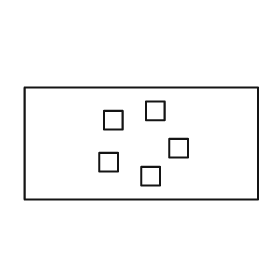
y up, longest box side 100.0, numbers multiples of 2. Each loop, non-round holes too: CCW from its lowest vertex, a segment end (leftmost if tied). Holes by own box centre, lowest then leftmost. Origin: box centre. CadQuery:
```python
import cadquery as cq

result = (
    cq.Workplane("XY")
    .moveTo(-50.0, -24.0)
    .lineTo(50.0, -24.0)
    .lineTo(50.0, 24.0)
    .lineTo(-50.0, 24.0)
    .close()
    .moveTo(0.0, -18.0)
    .lineTo(8.0, -18.0)
    .lineTo(8.0, -10.0)
    .lineTo(0.0, -10.0)
    .close()
    .moveTo(-18.0, -12.0)
    .lineTo(-10.0, -12.0)
    .lineTo(-10.0, -4.0)
    .lineTo(-18.0, -4.0)
    .close()
    .moveTo(12.0, -6.0)
    .lineTo(20.0, -6.0)
    .lineTo(20.0, 2.0)
    .lineTo(12.0, 2.0)
    .close()
    .moveTo(-16.0, 6.0)
    .lineTo(-8.0, 6.0)
    .lineTo(-8.0, 14.0)
    .lineTo(-16.0, 14.0)
    .close()
    .moveTo(2.0, 10.0)
    .lineTo(10.0, 10.0)
    .lineTo(10.0, 18.0)
    .lineTo(2.0, 18.0)
    .close()
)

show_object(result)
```